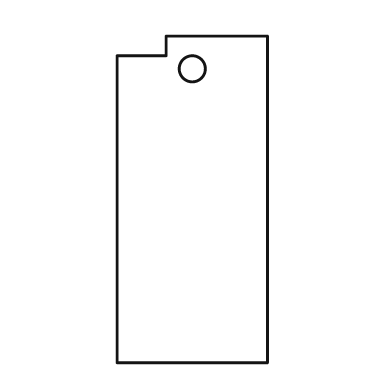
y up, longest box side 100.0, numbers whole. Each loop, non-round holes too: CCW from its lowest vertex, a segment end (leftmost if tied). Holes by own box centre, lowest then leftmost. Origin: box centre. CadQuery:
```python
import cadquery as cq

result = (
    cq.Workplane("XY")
    .moveTo(-23.0, -50.0)
    .lineTo(23.0, -50.0)
    .lineTo(23.0, 50.0)
    .lineTo(-8.0, 50.0)
    .lineTo(-8.0, 44.0)
    .lineTo(-23.0, 44.0)
    .close()
    .moveTo(0.0, 40.0)
    .circle(4.0)
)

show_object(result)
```